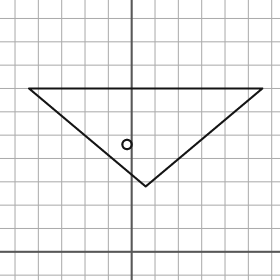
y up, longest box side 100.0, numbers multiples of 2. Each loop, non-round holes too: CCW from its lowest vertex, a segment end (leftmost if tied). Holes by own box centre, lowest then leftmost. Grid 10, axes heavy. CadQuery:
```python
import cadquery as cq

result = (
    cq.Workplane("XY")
    .moveTo(6.0, 28.0)
    .lineTo(56.0, 70.0)
    .lineTo(-44.0, 70.0)
    .close()
    .moveTo(-2.0, 46.0)
    .circle(2.0)
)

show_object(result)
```